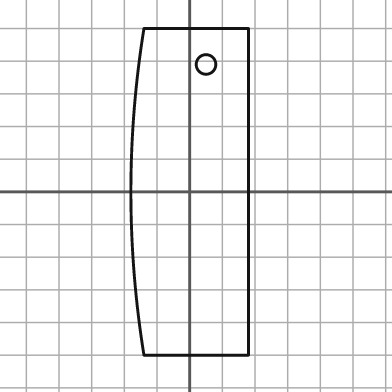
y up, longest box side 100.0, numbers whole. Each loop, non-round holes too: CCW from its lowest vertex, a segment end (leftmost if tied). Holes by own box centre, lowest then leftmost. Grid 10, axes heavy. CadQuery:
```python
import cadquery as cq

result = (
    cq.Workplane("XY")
    .moveTo(-14.0, -50.0)
    .lineTo(18.0, -50.0)
    .lineTo(18.0, 50.0)
    .lineTo(-14.0, 50.0)
    .threePointArc((-18.0, 0.0), (-14.0, -50.0))
    .close()
    .moveTo(5.0, 39.0)
    .circle(3.0)
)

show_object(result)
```